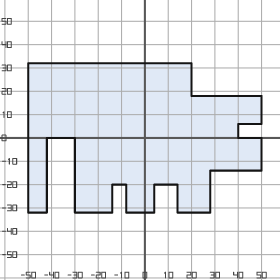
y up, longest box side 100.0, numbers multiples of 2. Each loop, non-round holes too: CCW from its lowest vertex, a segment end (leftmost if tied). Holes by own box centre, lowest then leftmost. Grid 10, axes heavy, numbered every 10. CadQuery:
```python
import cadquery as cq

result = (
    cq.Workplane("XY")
    .moveTo(-50.0, -32.0)
    .lineTo(-42.0, -32.0)
    .lineTo(-42.0, 0.0)
    .lineTo(-30.0, 0.0)
    .lineTo(-30.0, -32.0)
    .lineTo(-14.0, -32.0)
    .lineTo(-14.0, -20.0)
    .lineTo(-8.0, -20.0)
    .lineTo(-8.0, -32.0)
    .lineTo(4.0, -32.0)
    .lineTo(4.0, -20.0)
    .lineTo(14.0, -20.0)
    .lineTo(14.0, -32.0)
    .lineTo(28.0, -32.0)
    .lineTo(28.0, -14.0)
    .lineTo(50.0, -14.0)
    .lineTo(50.0, 0.0)
    .lineTo(40.0, 0.0)
    .lineTo(40.0, 6.0)
    .lineTo(50.0, 6.0)
    .lineTo(50.0, 18.0)
    .lineTo(20.0, 18.0)
    .lineTo(20.0, 32.0)
    .lineTo(-50.0, 32.0)
    .close()
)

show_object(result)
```